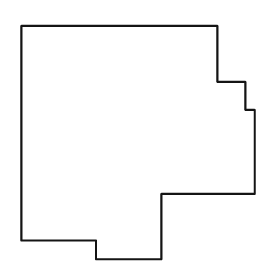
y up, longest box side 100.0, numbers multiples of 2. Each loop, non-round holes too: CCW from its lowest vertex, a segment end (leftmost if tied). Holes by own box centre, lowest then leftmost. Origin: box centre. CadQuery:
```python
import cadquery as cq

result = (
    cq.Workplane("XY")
    .moveTo(-18.0, -50.0)
    .lineTo(10.0, -50.0)
    .lineTo(10.0, -22.0)
    .lineTo(50.0, -22.0)
    .lineTo(50.0, 14.0)
    .lineTo(46.0, 14.0)
    .lineTo(46.0, 26.0)
    .lineTo(34.0, 26.0)
    .lineTo(34.0, 50.0)
    .lineTo(-50.0, 50.0)
    .lineTo(-50.0, -42.0)
    .lineTo(-18.0, -42.0)
    .close()
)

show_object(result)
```